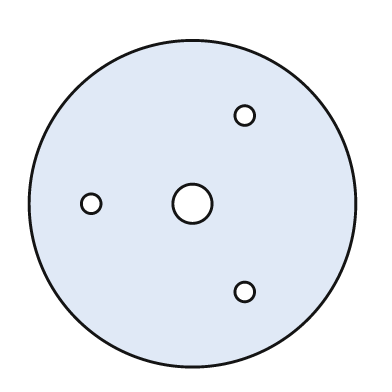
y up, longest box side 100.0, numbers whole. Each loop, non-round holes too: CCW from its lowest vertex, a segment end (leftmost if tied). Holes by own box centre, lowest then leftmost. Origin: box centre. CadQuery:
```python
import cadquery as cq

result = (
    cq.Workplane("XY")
    .moveTo(0.0, 0.0)
    .circle(50.0)
    .moveTo(16.0, -27.0)
    .circle(3.0)
    .moveTo(-31.0, 0.0)
    .circle(3.0)
    .moveTo(0.0, 0.0)
    .circle(6.0)
    .moveTo(16.0, 27.0)
    .circle(3.0)
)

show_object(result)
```